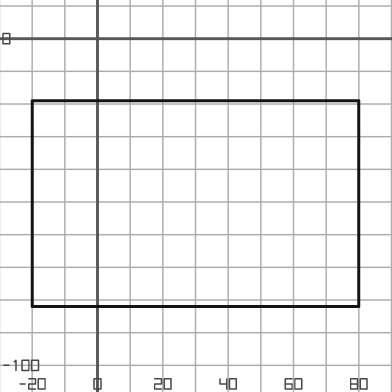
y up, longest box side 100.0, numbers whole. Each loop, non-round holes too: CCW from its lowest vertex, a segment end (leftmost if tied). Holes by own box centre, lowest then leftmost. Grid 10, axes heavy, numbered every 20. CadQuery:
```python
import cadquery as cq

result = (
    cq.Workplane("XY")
    .moveTo(-20.0, -82.0)
    .lineTo(80.0, -82.0)
    .lineTo(80.0, -19.0)
    .lineTo(-20.0, -19.0)
    .close()
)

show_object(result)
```